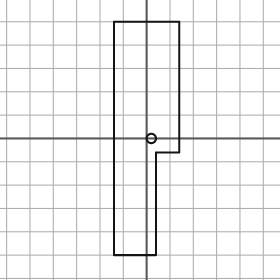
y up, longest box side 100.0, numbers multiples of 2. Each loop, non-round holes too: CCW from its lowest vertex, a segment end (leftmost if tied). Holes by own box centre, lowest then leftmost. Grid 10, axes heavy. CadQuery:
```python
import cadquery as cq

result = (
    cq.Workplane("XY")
    .moveTo(-14.0, -50.0)
    .lineTo(4.0, -50.0)
    .lineTo(4.0, -6.0)
    .lineTo(14.0, -6.0)
    .lineTo(14.0, 50.0)
    .lineTo(-14.0, 50.0)
    .close()
    .moveTo(2.0, 0.0)
    .circle(2.0)
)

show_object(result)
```